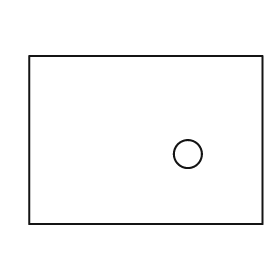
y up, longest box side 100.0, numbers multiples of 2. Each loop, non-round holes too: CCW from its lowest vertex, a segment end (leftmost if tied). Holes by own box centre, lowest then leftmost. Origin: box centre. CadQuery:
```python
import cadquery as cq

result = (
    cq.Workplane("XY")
    .moveTo(-50.0, -36.0)
    .lineTo(50.0, -36.0)
    .lineTo(50.0, 36.0)
    .lineTo(-50.0, 36.0)
    .close()
    .moveTo(18.0, -6.0)
    .circle(6.0)
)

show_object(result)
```